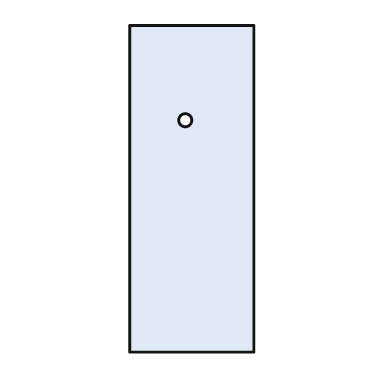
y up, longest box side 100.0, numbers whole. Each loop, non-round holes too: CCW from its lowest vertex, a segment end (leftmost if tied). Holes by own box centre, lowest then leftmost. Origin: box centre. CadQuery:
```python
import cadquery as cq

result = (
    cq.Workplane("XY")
    .moveTo(-19.0, -50.0)
    .lineTo(19.0, -50.0)
    .lineTo(19.0, 50.0)
    .lineTo(-19.0, 50.0)
    .close()
    .moveTo(-2.0, 21.0)
    .circle(2.0)
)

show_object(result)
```